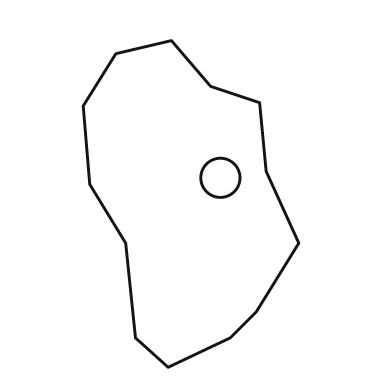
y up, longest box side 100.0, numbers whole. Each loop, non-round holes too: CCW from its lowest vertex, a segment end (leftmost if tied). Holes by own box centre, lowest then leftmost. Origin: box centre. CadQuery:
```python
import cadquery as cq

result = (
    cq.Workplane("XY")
    .moveTo(-7.0, -50.0)
    .lineTo(12.0, -41.0)
    .lineTo(20.0, -33.0)
    .lineTo(33.0, -12.0)
    .lineTo(23.0, 10.0)
    .lineTo(21.0, 31.0)
    .lineTo(6.0, 36.0)
    .lineTo(-6.0, 50.0)
    .lineTo(-23.0, 46.0)
    .lineTo(-33.0, 30.0)
    .lineTo(-31.0, 6.0)
    .lineTo(-20.0, -12.0)
    .lineTo(-17.0, -41.0)
    .close()
    .moveTo(9.0, 8.0)
    .circle(6.0)
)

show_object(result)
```